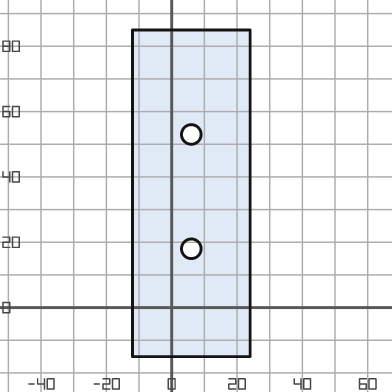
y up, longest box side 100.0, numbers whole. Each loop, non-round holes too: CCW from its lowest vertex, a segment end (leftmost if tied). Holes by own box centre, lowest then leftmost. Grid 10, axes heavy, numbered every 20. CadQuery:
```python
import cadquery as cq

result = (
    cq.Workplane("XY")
    .moveTo(-12.0, -15.0)
    .lineTo(24.0, -15.0)
    .lineTo(24.0, 85.0)
    .lineTo(-12.0, 85.0)
    .close()
    .moveTo(6.0, 18.0)
    .circle(3.0)
    .moveTo(6.0, 53.0)
    .circle(3.0)
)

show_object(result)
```